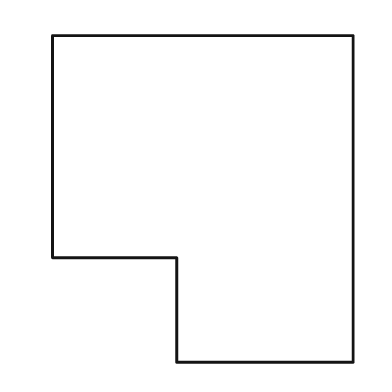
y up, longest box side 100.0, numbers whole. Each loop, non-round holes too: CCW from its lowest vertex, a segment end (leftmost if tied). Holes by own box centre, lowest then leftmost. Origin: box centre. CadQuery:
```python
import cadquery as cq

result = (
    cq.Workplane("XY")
    .moveTo(-8.0, -50.0)
    .lineTo(46.0, -50.0)
    .lineTo(46.0, 50.0)
    .lineTo(-46.0, 50.0)
    .lineTo(-46.0, -18.0)
    .lineTo(-8.0, -18.0)
    .close()
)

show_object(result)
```